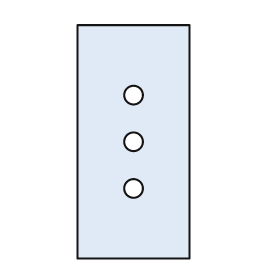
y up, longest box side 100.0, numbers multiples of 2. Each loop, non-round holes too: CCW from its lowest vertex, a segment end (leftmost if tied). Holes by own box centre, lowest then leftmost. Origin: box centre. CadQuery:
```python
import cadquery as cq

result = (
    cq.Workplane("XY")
    .moveTo(-24.0, -50.0)
    .lineTo(24.0, -50.0)
    .lineTo(24.0, 50.0)
    .lineTo(-24.0, 50.0)
    .close()
    .moveTo(0.0, -20.0)
    .circle(4.0)
    .moveTo(0.0, 0.0)
    .circle(4.0)
    .moveTo(0.0, 20.0)
    .circle(4.0)
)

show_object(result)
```